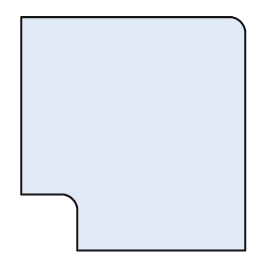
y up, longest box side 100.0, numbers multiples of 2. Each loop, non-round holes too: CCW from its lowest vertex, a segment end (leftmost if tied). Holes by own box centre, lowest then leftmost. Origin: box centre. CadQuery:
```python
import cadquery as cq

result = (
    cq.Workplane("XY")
    .moveTo(-24.0, -50.0)
    .lineTo(48.0, -50.0)
    .lineTo(48.0, 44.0)
    .threePointArc((46.0, 48.0), (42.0, 50.0))
    .lineTo(-48.0, 50.0)
    .lineTo(-48.0, -26.0)
    .lineTo(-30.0, -26.0)
    .threePointArc((-26.0, -28.0), (-24.0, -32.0))
    .close()
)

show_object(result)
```